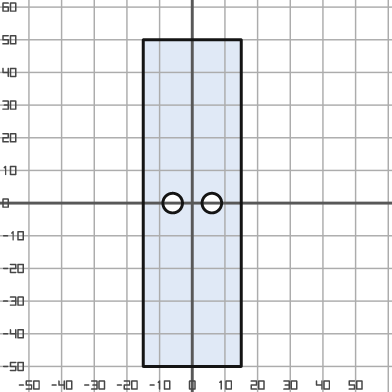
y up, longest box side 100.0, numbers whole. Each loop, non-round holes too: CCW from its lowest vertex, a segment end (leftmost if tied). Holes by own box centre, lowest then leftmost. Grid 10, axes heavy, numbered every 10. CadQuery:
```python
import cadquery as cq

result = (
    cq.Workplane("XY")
    .moveTo(-15.0, -50.0)
    .lineTo(15.0, -50.0)
    .lineTo(15.0, 50.0)
    .lineTo(-15.0, 50.0)
    .close()
    .moveTo(-6.0, 0.0)
    .circle(3.0)
    .moveTo(6.0, 0.0)
    .circle(3.0)
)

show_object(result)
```